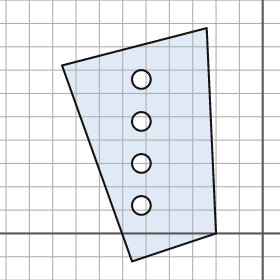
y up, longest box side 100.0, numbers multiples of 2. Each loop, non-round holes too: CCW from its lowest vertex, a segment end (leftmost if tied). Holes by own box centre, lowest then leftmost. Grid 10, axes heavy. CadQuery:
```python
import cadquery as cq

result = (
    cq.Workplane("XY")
    .moveTo(-56.0, -12.0)
    .lineTo(-20.0, 0.0)
    .lineTo(-24.0, 88.0)
    .lineTo(-86.0, 72.0)
    .close()
    .moveTo(-52.0, 12.0)
    .circle(4.0)
    .moveTo(-52.0, 30.0)
    .circle(4.0)
    .moveTo(-52.0, 48.0)
    .circle(4.0)
    .moveTo(-52.0, 66.0)
    .circle(4.0)
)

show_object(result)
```